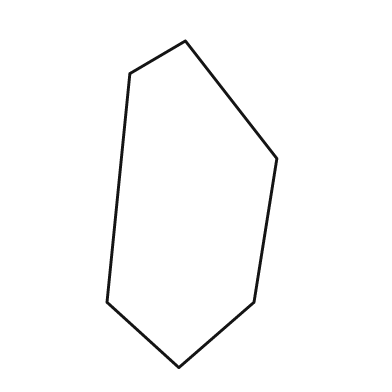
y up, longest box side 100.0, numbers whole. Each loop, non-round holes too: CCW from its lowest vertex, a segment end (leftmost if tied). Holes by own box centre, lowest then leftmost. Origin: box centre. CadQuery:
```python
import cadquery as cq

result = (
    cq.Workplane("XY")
    .moveTo(-4.0, -50.0)
    .lineTo(19.0, -30.0)
    .lineTo(26.0, 14.0)
    .lineTo(-2.0, 50.0)
    .lineTo(-19.0, 40.0)
    .lineTo(-26.0, -30.0)
    .close()
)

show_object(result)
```